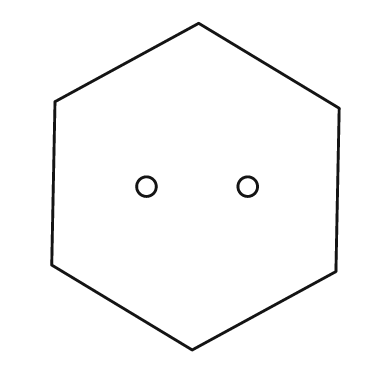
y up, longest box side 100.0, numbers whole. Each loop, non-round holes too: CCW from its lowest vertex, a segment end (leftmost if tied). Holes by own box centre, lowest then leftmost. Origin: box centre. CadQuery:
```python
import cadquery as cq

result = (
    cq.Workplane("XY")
    .moveTo(-1.0, -50.0)
    .lineTo(43.0, -26.0)
    .lineTo(44.0, 24.0)
    .lineTo(1.0, 50.0)
    .lineTo(-43.0, 26.0)
    .lineTo(-44.0, -24.0)
    .close()
    .moveTo(-15.0, 0.0)
    .circle(3.0)
    .moveTo(16.0, 0.0)
    .circle(3.0)
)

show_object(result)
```